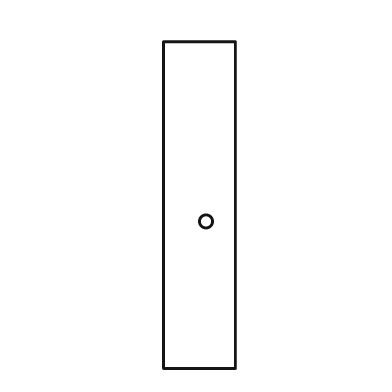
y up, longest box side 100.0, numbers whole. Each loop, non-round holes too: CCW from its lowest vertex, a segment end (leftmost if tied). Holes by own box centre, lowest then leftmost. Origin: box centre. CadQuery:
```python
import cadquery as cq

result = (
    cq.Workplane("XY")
    .moveTo(-11.0, -50.0)
    .lineTo(11.0, -50.0)
    .lineTo(11.0, 50.0)
    .lineTo(-11.0, 50.0)
    .close()
    .moveTo(2.0, -5.0)
    .circle(2.0)
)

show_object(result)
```